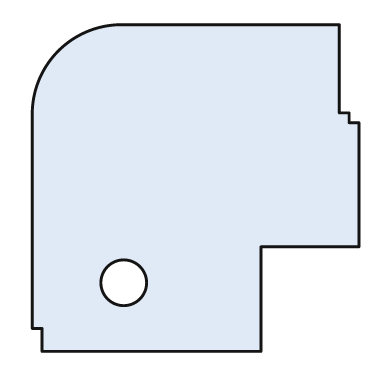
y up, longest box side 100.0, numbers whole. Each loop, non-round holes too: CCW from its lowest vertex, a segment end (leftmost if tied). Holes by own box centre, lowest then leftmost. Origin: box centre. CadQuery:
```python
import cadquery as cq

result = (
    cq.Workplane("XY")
    .moveTo(-47.0, -50.0)
    .lineTo(20.0, -50.0)
    .lineTo(20.0, -18.0)
    .lineTo(50.0, -18.0)
    .lineTo(50.0, 20.0)
    .lineTo(47.0, 20.0)
    .lineTo(47.0, 23.0)
    .lineTo(44.0, 23.0)
    .lineTo(44.0, 50.0)
    .lineTo(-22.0, 50.0)
    .threePointArc((-42.0, 42.0), (-50.0, 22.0))
    .lineTo(-50.0, -43.0)
    .lineTo(-47.0, -43.0)
    .close()
    .moveTo(-22.0, -29.0)
    .circle(7.0)
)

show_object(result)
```